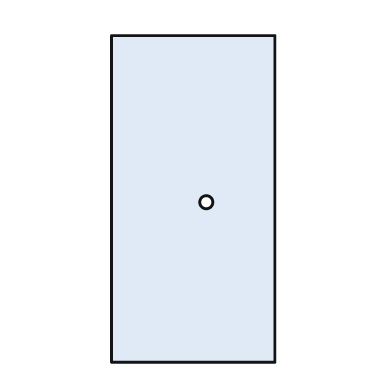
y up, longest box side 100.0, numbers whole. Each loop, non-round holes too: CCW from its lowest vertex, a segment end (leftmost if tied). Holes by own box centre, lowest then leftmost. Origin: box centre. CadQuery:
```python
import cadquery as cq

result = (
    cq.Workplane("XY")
    .moveTo(-25.0, -50.0)
    .lineTo(25.0, -50.0)
    .lineTo(25.0, 50.0)
    .lineTo(-25.0, 50.0)
    .close()
    .moveTo(4.0, -1.0)
    .circle(2.0)
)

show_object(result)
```